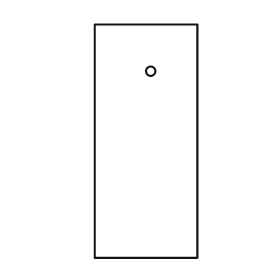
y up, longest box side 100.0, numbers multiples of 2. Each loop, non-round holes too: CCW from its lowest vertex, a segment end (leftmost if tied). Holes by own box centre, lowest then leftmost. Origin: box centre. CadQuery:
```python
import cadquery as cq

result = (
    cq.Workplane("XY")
    .moveTo(-22.0, -50.0)
    .lineTo(22.0, -50.0)
    .lineTo(22.0, 50.0)
    .lineTo(-22.0, 50.0)
    .close()
    .moveTo(2.0, 30.0)
    .circle(2.0)
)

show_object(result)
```